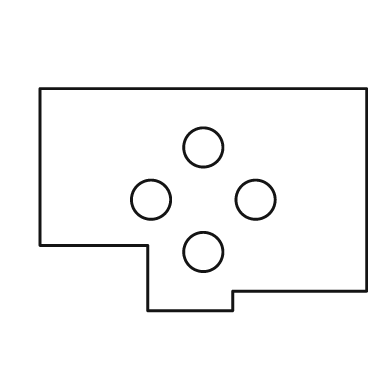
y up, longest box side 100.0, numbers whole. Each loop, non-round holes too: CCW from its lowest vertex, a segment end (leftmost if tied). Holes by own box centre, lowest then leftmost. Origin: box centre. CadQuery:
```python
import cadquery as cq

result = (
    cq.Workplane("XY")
    .moveTo(-17.0, -34.0)
    .lineTo(9.0, -34.0)
    .lineTo(9.0, -28.0)
    .lineTo(50.0, -28.0)
    .lineTo(50.0, 34.0)
    .lineTo(-50.0, 34.0)
    .lineTo(-50.0, -14.0)
    .lineTo(-17.0, -14.0)
    .close()
    .moveTo(0.0, -16.0)
    .circle(6.0)
    .moveTo(-16.0, 0.0)
    .circle(6.0)
    .moveTo(16.0, 0.0)
    .circle(6.0)
    .moveTo(0.0, 16.0)
    .circle(6.0)
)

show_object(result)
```